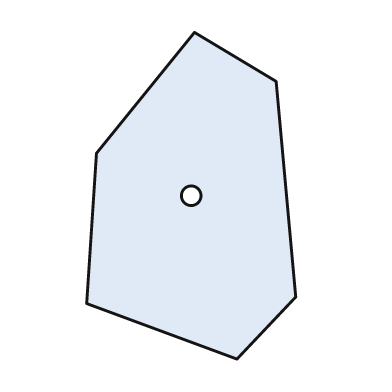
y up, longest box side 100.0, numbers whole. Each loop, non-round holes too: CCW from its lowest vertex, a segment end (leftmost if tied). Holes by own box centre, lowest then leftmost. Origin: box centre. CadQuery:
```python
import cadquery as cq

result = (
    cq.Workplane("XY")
    .moveTo(14.0, -50.0)
    .lineTo(32.0, -31.0)
    .lineTo(26.0, 35.0)
    .lineTo(1.0, 50.0)
    .lineTo(-29.0, 13.0)
    .lineTo(-32.0, -33.0)
    .close()
    .moveTo(0.0, 0.0)
    .circle(3.0)
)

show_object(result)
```